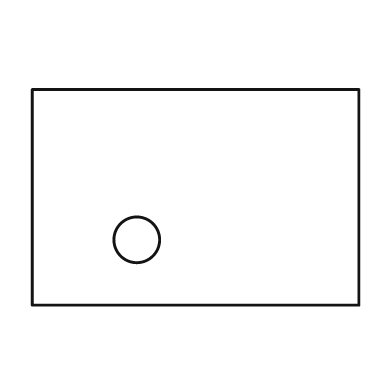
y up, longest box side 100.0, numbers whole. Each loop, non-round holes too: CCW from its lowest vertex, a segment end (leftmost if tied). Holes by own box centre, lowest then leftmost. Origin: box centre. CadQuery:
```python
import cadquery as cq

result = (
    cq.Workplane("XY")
    .moveTo(-50.0, -33.0)
    .lineTo(50.0, -33.0)
    .lineTo(50.0, 33.0)
    .lineTo(-50.0, 33.0)
    .close()
    .moveTo(-18.0, -13.0)
    .circle(7.0)
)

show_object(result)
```